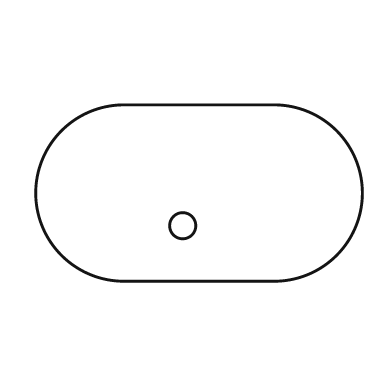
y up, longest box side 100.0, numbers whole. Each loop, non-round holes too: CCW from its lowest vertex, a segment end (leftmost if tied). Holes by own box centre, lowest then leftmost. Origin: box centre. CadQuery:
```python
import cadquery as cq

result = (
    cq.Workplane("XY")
    .moveTo(-23.0, -27.0)
    .lineTo(23.0, -27.0)
    .threePointArc((50.0, 0.0), (23.0, 27.0))
    .lineTo(-23.0, 27.0)
    .threePointArc((-50.0, 0.0), (-23.0, -27.0))
    .close()
    .moveTo(-5.0, -10.0)
    .circle(4.0)
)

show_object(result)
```